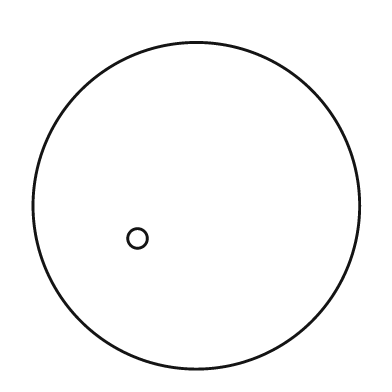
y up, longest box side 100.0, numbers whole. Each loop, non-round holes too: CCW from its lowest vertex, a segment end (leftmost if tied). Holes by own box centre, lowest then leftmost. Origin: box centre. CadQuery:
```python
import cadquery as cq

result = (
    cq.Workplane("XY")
    .moveTo(0.0, 0.0)
    .circle(50.0)
    .moveTo(-18.0, -10.0)
    .circle(3.0)
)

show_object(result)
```